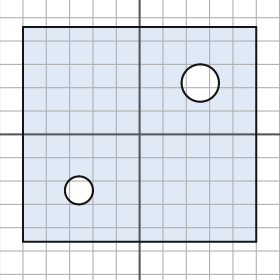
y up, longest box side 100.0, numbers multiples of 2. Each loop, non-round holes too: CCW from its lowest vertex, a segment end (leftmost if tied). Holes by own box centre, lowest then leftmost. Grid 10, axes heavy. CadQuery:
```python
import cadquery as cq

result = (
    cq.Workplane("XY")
    .moveTo(-50.0, -46.0)
    .lineTo(50.0, -46.0)
    .lineTo(50.0, 46.0)
    .lineTo(-50.0, 46.0)
    .close()
    .moveTo(-26.0, -24.0)
    .circle(6.0)
    .moveTo(26.0, 22.0)
    .circle(8.0)
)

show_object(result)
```